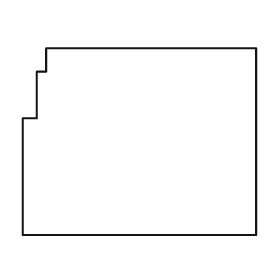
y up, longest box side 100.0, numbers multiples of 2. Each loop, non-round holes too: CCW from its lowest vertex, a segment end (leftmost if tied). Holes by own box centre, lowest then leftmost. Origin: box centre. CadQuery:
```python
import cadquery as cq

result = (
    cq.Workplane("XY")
    .moveTo(-50.0, -40.0)
    .lineTo(50.0, -40.0)
    .lineTo(50.0, 40.0)
    .lineTo(-40.0, 40.0)
    .lineTo(-40.0, 30.0)
    .lineTo(-44.0, 30.0)
    .lineTo(-44.0, 10.0)
    .lineTo(-50.0, 10.0)
    .close()
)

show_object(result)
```